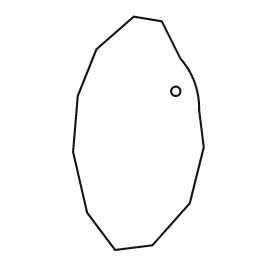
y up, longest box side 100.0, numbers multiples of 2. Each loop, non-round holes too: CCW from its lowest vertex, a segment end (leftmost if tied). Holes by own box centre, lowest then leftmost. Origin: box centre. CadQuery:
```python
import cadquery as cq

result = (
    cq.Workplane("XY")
    .moveTo(-10.0, -50.0)
    .lineTo(6.0, -48.0)
    .lineTo(22.0, -30.0)
    .lineTo(28.0, -6.0)
    .lineTo(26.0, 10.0)
    .threePointArc((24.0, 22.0), (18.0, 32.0))
    .lineTo(10.0, 48.0)
    .lineTo(-2.0, 50.0)
    .lineTo(-18.0, 36.0)
    .lineTo(-26.0, 16.0)
    .lineTo(-28.0, -8.0)
    .lineTo(-22.0, -34.0)
    .close()
    .moveTo(16.0, 18.0)
    .circle(2.0)
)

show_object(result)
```